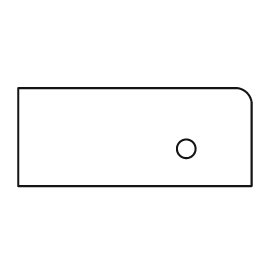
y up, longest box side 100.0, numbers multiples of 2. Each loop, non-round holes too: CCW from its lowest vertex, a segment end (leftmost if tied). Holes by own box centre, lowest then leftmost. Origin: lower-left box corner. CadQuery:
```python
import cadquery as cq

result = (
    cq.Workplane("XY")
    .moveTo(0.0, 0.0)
    .lineTo(100.0, 0.0)
    .lineTo(100.0, 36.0)
    .threePointArc((98.0, 40.0), (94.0, 42.0))
    .lineTo(0.0, 42.0)
    .close()
    .moveTo(72.0, 16.0)
    .circle(4.0)
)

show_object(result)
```